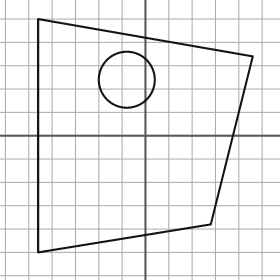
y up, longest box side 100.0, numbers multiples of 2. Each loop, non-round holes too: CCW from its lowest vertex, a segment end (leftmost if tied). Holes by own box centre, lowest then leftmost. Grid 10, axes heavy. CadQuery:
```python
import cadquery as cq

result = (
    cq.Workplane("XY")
    .moveTo(-46.0, -50.0)
    .lineTo(28.0, -38.0)
    .lineTo(46.0, 34.0)
    .lineTo(-46.0, 50.0)
    .close()
    .moveTo(-8.0, 24.0)
    .circle(12.0)
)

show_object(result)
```